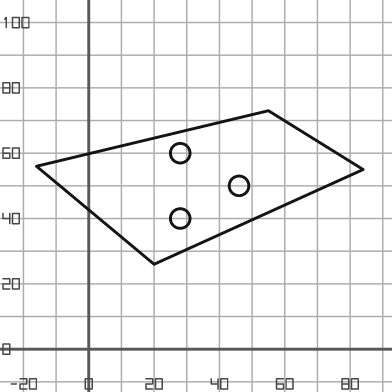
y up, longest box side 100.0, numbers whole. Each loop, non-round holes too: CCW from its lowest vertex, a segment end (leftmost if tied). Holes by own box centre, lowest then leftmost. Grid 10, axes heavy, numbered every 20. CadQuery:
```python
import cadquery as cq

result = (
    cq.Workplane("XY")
    .moveTo(20.0, 26.0)
    .lineTo(84.0, 55.0)
    .lineTo(55.0, 73.0)
    .lineTo(-16.0, 56.0)
    .close()
    .moveTo(28.0, 40.0)
    .circle(3.0)
    .moveTo(46.0, 50.0)
    .circle(3.0)
    .moveTo(28.0, 60.0)
    .circle(3.0)
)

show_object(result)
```